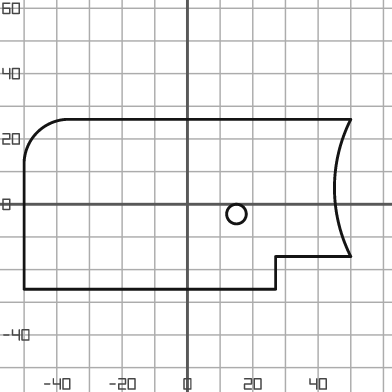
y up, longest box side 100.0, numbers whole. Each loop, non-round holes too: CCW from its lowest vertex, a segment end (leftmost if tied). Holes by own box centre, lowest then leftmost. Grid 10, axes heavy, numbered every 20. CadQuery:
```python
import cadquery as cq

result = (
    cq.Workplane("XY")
    .moveTo(-50.0, -26.0)
    .lineTo(27.0, -26.0)
    .lineTo(27.0, -16.0)
    .lineTo(50.0, -16.0)
    .threePointArc((45.0, 5.0), (50.0, 26.0))
    .lineTo(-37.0, 26.0)
    .threePointArc((-46.0, 22.0), (-50.0, 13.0))
    .close()
    .moveTo(15.0, -3.0)
    .circle(3.0)
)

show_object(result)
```